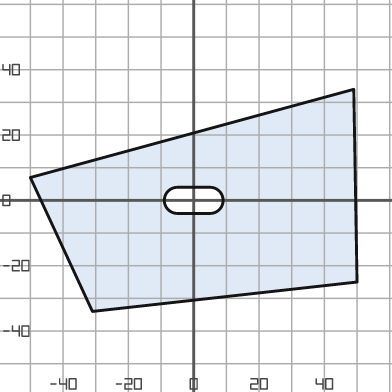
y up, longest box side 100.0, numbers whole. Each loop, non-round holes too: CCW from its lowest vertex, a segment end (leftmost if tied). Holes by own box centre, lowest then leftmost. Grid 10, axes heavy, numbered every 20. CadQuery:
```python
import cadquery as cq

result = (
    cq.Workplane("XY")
    .moveTo(-31.0, -34.0)
    .lineTo(50.0, -25.0)
    .lineTo(49.0, 34.0)
    .lineTo(-50.0, 7.0)
    .close()
    .moveTo(-5.0, -4.0)
    .lineTo(5.0, -4.0)
    .threePointArc((9.0, 0.0), (5.0, 4.0))
    .lineTo(-5.0, 4.0)
    .threePointArc((-9.0, 0.0), (-5.0, -4.0))
    .close()
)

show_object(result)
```